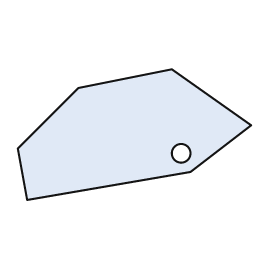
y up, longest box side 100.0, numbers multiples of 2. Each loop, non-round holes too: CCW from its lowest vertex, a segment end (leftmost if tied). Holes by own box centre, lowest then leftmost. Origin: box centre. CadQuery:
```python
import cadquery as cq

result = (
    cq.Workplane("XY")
    .moveTo(-46.0, -28.0)
    .lineTo(24.0, -16.0)
    .lineTo(50.0, 4.0)
    .lineTo(16.0, 28.0)
    .lineTo(-24.0, 20.0)
    .lineTo(-50.0, -6.0)
    .close()
    .moveTo(20.0, -8.0)
    .circle(4.0)
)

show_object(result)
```